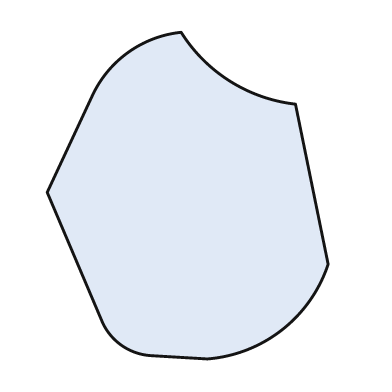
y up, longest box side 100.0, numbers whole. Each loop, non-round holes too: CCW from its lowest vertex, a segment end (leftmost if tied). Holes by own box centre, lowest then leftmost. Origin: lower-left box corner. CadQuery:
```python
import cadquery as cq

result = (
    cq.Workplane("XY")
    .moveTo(49.0, 0.0)
    .threePointArc((72.0, 9.0), (86.0, 29.0))
    .lineTo(76.0, 78.0)
    .threePointArc((56.0, 85.0), (41.0, 100.0))
    .threePointArc((25.0, 94.0), (14.0, 81.0))
    .lineTo(0.0, 51.0)
    .lineTo(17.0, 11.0)
    .threePointArc((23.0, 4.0), (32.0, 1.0))
    .close()
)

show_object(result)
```